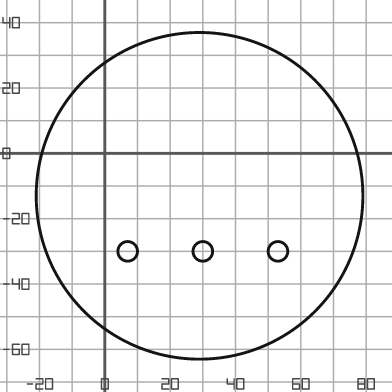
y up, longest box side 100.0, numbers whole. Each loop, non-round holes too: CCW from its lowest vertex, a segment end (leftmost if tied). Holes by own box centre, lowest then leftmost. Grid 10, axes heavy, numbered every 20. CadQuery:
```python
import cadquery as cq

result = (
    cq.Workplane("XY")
    .moveTo(29.0, -13.0)
    .circle(50.0)
    .moveTo(7.0, -30.0)
    .circle(3.0)
    .moveTo(30.0, -30.0)
    .circle(3.0)
    .moveTo(53.0, -30.0)
    .circle(3.0)
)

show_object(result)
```